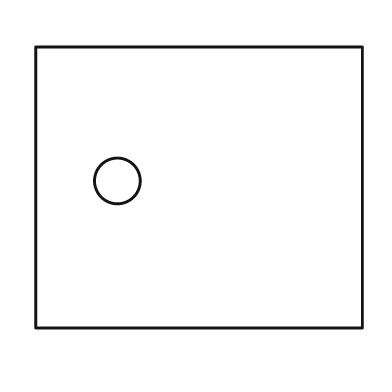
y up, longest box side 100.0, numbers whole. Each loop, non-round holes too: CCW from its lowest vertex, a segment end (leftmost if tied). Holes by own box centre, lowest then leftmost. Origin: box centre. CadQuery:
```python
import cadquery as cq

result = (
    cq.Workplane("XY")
    .moveTo(-50.0, -43.0)
    .lineTo(50.0, -43.0)
    .lineTo(50.0, 43.0)
    .lineTo(-50.0, 43.0)
    .close()
    .moveTo(-25.0, 2.0)
    .circle(7.0)
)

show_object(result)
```